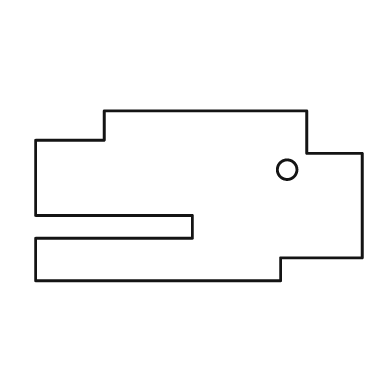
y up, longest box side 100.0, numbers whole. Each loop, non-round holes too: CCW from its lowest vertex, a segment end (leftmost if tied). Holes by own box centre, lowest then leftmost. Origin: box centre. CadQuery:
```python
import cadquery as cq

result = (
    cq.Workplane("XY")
    .moveTo(-50.0, -26.0)
    .lineTo(25.0, -26.0)
    .lineTo(25.0, -19.0)
    .lineTo(50.0, -19.0)
    .lineTo(50.0, 13.0)
    .lineTo(33.0, 13.0)
    .lineTo(33.0, 26.0)
    .lineTo(-29.0, 26.0)
    .lineTo(-29.0, 17.0)
    .lineTo(-50.0, 17.0)
    .lineTo(-50.0, -6.0)
    .lineTo(-2.0, -6.0)
    .lineTo(-2.0, -13.0)
    .lineTo(-50.0, -13.0)
    .close()
    .moveTo(27.0, 8.0)
    .circle(3.0)
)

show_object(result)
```